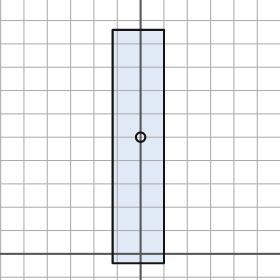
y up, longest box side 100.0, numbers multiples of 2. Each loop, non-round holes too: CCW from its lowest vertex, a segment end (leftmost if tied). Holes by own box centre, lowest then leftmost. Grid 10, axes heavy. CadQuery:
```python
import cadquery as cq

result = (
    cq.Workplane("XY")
    .moveTo(-12.0, -4.0)
    .lineTo(10.0, -4.0)
    .lineTo(10.0, 96.0)
    .lineTo(-12.0, 96.0)
    .close()
    .moveTo(0.0, 50.0)
    .circle(2.0)
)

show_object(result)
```